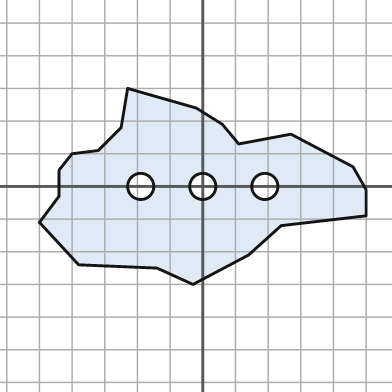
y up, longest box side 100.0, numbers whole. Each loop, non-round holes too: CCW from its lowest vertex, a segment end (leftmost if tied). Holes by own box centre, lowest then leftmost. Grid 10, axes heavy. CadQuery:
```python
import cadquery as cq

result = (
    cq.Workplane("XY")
    .moveTo(-3.0, -30.0)
    .lineTo(14.0, -21.0)
    .lineTo(24.0, -12.0)
    .lineTo(50.0, -9.0)
    .lineTo(50.0, -1.0)
    .lineTo(46.0, 6.0)
    .lineTo(27.0, 16.0)
    .lineTo(11.0, 13.0)
    .lineTo(6.0, 19.0)
    .lineTo(-2.0, 24.0)
    .lineTo(-23.0, 30.0)
    .lineTo(-25.0, 18.0)
    .lineTo(-32.0, 11.0)
    .lineTo(-40.0, 10.0)
    .lineTo(-44.0, 5.0)
    .lineTo(-44.0, -3.0)
    .lineTo(-50.0, -11.0)
    .lineTo(-38.0, -24.0)
    .lineTo(-14.0, -25.0)
    .close()
    .moveTo(-19.0, 0.0)
    .circle(4.0)
    .moveTo(0.0, 0.0)
    .circle(4.0)
    .moveTo(19.0, 0.0)
    .circle(4.0)
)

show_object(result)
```